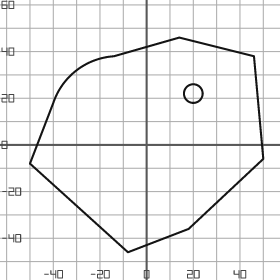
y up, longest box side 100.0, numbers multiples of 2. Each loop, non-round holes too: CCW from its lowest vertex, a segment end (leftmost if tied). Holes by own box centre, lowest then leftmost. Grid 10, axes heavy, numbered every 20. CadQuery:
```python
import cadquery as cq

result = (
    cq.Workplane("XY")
    .moveTo(-8.0, -46.0)
    .lineTo(18.0, -36.0)
    .lineTo(50.0, -6.0)
    .lineTo(46.0, 38.0)
    .lineTo(14.0, 46.0)
    .lineTo(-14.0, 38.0)
    .threePointArc((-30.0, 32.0), (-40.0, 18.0))
    .lineTo(-50.0, -8.0)
    .close()
    .moveTo(20.0, 22.0)
    .circle(4.0)
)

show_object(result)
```